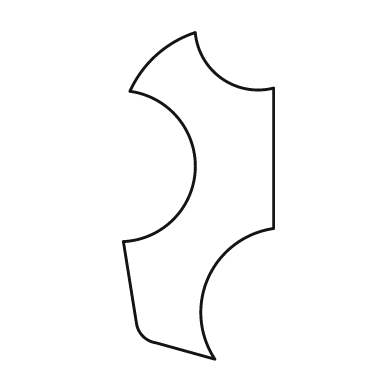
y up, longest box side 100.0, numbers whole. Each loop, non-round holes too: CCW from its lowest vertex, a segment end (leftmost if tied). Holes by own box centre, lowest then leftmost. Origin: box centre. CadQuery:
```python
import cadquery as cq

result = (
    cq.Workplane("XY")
    .moveTo(5.0, -50.0)
    .threePointArc((3.0, -25.0), (23.0, -10.0))
    .lineTo(23.0, 33.0)
    .threePointArc((7.0, 36.0), (-1.0, 50.0))
    .threePointArc((-13.0, 43.0), (-21.0, 32.0))
    .threePointArc((-1.0, 8.0), (-23.0, -14.0))
    .lineTo(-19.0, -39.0)
    .threePointArc((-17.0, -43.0), (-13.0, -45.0))
    .close()
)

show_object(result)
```